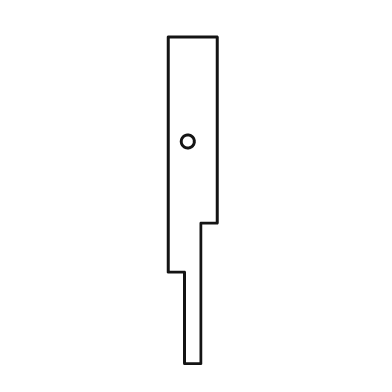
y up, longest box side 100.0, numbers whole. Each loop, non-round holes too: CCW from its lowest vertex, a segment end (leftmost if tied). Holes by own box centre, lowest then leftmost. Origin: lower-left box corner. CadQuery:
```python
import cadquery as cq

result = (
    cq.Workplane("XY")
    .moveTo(5.0, 0.0)
    .lineTo(10.0, 0.0)
    .lineTo(10.0, 43.0)
    .lineTo(15.0, 43.0)
    .lineTo(15.0, 100.0)
    .lineTo(0.0, 100.0)
    .lineTo(0.0, 28.0)
    .lineTo(5.0, 28.0)
    .close()
    .moveTo(6.0, 68.0)
    .circle(2.0)
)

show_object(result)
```